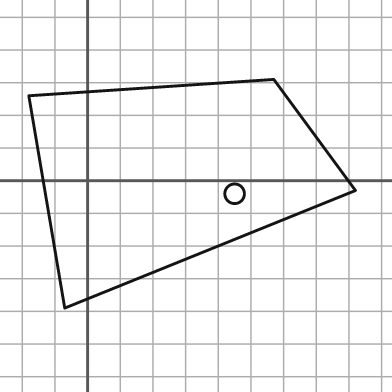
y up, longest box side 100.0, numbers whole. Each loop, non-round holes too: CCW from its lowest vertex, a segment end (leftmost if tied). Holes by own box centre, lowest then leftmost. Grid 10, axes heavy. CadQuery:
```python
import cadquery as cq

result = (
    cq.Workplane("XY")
    .moveTo(-7.0, -39.0)
    .lineTo(82.0, -3.0)
    .lineTo(57.0, 31.0)
    .lineTo(-18.0, 26.0)
    .close()
    .moveTo(45.0, -4.0)
    .circle(3.0)
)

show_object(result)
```